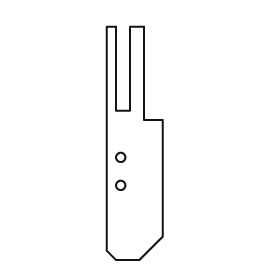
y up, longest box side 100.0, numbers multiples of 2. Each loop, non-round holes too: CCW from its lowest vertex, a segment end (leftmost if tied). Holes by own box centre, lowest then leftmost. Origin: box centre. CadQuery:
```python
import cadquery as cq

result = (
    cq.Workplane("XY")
    .moveTo(-8.0, -50.0)
    .lineTo(2.0, -50.0)
    .lineTo(12.0, -40.0)
    .lineTo(12.0, 10.0)
    .lineTo(4.0, 10.0)
    .lineTo(4.0, 50.0)
    .lineTo(-2.0, 50.0)
    .lineTo(-2.0, 14.0)
    .lineTo(-8.0, 14.0)
    .lineTo(-8.0, 50.0)
    .lineTo(-12.0, 50.0)
    .lineTo(-12.0, -46.0)
    .close()
    .moveTo(-6.0, -18.0)
    .circle(2.0)
    .moveTo(-6.0, -6.0)
    .circle(2.0)
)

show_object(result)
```